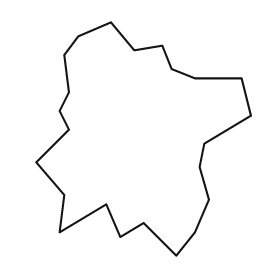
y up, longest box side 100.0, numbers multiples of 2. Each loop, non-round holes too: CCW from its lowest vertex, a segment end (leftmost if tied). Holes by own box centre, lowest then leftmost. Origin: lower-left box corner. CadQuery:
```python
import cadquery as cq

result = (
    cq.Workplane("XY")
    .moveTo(60.0, 0.0)
    .lineTo(68.0, 10.0)
    .lineTo(74.0, 24.0)
    .lineTo(70.0, 38.0)
    .lineTo(72.0, 48.0)
    .lineTo(92.0, 60.0)
    .lineTo(88.0, 76.0)
    .lineTo(68.0, 76.0)
    .lineTo(58.0, 80.0)
    .lineTo(54.0, 90.0)
    .lineTo(42.0, 88.0)
    .lineTo(32.0, 100.0)
    .lineTo(18.0, 94.0)
    .lineTo(12.0, 86.0)
    .lineTo(14.0, 70.0)
    .lineTo(10.0, 62.0)
    .lineTo(14.0, 54.0)
    .lineTo(0.0, 40.0)
    .lineTo(12.0, 26.0)
    .lineTo(10.0, 10.0)
    .lineTo(30.0, 22.0)
    .lineTo(36.0, 8.0)
    .lineTo(46.0, 14.0)
    .close()
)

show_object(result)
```